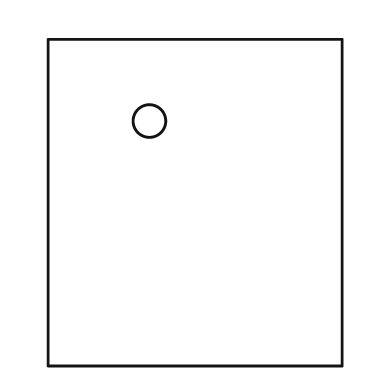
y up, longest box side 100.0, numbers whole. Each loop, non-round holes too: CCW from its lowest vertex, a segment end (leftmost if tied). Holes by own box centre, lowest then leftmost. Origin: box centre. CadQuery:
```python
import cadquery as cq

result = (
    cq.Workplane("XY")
    .moveTo(-45.0, -50.0)
    .lineTo(45.0, -50.0)
    .lineTo(45.0, 50.0)
    .lineTo(-45.0, 50.0)
    .close()
    .moveTo(-14.0, 25.0)
    .circle(5.0)
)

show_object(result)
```